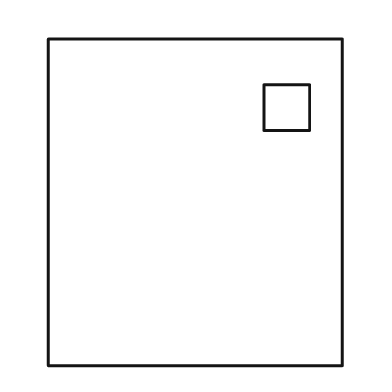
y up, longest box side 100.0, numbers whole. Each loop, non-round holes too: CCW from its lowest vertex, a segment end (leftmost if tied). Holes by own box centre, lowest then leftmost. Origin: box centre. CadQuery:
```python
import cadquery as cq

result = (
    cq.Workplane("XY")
    .moveTo(-45.0, -50.0)
    .lineTo(45.0, -50.0)
    .lineTo(45.0, 50.0)
    .lineTo(-45.0, 50.0)
    .close()
    .moveTo(21.0, 22.0)
    .lineTo(35.0, 22.0)
    .lineTo(35.0, 36.0)
    .lineTo(21.0, 36.0)
    .close()
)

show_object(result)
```